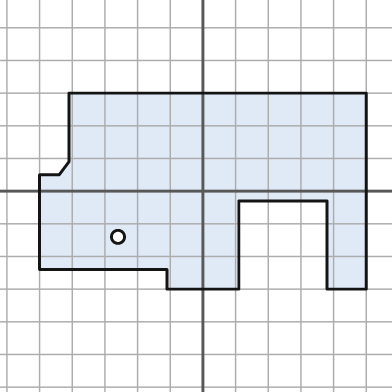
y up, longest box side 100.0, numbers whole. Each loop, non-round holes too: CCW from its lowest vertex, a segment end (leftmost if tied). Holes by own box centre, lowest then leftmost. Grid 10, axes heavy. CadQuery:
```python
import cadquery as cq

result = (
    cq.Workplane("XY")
    .moveTo(-11.0, -30.0)
    .lineTo(11.0, -30.0)
    .lineTo(11.0, -3.0)
    .lineTo(38.0, -3.0)
    .lineTo(38.0, -30.0)
    .lineTo(50.0, -30.0)
    .lineTo(50.0, 30.0)
    .lineTo(-41.0, 30.0)
    .lineTo(-41.0, 9.0)
    .lineTo(-44.0, 5.0)
    .lineTo(-50.0, 5.0)
    .lineTo(-50.0, -24.0)
    .lineTo(-11.0, -24.0)
    .close()
    .moveTo(-26.0, -14.0)
    .circle(2.0)
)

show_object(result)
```